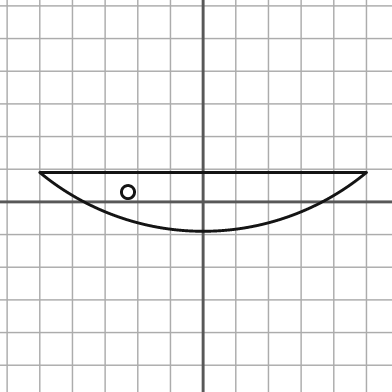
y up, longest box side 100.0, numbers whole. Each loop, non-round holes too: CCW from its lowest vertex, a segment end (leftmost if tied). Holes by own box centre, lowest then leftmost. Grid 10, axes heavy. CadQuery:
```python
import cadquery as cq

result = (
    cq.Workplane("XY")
    .moveTo(-50.0, 9.0)
    .threePointArc((0.0, -9.0), (50.0, 9.0))
    .close()
    .moveTo(-23.0, 3.0)
    .circle(2.0)
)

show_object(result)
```